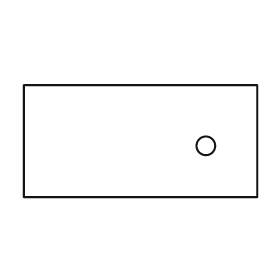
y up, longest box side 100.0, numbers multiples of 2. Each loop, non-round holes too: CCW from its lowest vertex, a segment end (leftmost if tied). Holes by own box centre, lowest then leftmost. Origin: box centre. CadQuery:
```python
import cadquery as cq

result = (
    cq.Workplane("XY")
    .moveTo(-50.0, -24.0)
    .lineTo(50.0, -24.0)
    .lineTo(50.0, 24.0)
    .lineTo(-50.0, 24.0)
    .close()
    .moveTo(28.0, -2.0)
    .circle(4.0)
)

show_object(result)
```